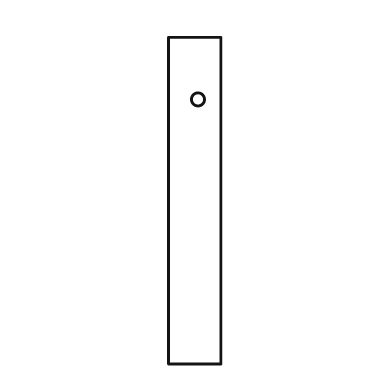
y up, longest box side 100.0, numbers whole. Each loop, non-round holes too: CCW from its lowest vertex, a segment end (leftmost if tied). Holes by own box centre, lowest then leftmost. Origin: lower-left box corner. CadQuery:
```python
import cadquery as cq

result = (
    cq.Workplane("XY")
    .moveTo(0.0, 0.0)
    .lineTo(16.0, 0.0)
    .lineTo(16.0, 100.0)
    .lineTo(0.0, 100.0)
    .close()
    .moveTo(9.0, 81.0)
    .circle(2.0)
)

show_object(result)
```